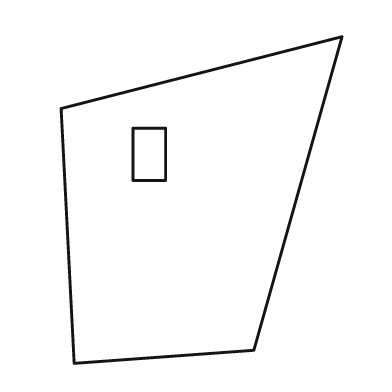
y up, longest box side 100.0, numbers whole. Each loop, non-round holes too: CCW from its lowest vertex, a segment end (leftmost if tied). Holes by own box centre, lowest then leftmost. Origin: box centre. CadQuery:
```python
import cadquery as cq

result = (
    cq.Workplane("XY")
    .moveTo(-39.0, -50.0)
    .lineTo(16.0, -46.0)
    .lineTo(43.0, 50.0)
    .lineTo(-43.0, 28.0)
    .close()
    .moveTo(-21.0, 6.0)
    .lineTo(-11.0, 6.0)
    .lineTo(-11.0, 22.0)
    .lineTo(-21.0, 22.0)
    .close()
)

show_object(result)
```